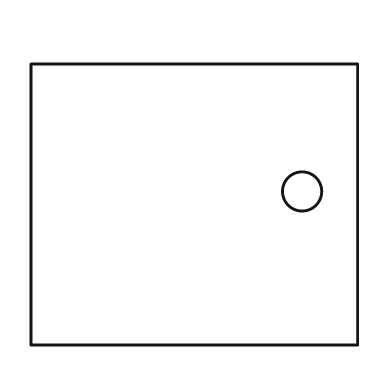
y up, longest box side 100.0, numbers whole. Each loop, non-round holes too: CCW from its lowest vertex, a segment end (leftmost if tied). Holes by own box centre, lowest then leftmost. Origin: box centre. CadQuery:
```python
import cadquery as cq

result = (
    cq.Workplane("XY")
    .moveTo(-50.0, -43.0)
    .lineTo(50.0, -43.0)
    .lineTo(50.0, 43.0)
    .lineTo(-50.0, 43.0)
    .close()
    .moveTo(33.0, 4.0)
    .circle(6.0)
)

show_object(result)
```